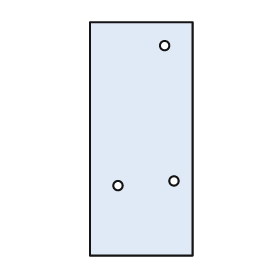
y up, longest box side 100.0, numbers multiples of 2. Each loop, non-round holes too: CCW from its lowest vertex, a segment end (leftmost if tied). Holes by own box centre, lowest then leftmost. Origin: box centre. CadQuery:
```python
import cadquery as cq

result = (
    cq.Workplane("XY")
    .moveTo(-22.0, -50.0)
    .lineTo(22.0, -50.0)
    .lineTo(22.0, 50.0)
    .lineTo(-22.0, 50.0)
    .close()
    .moveTo(-10.0, -20.0)
    .circle(2.0)
    .moveTo(14.0, -18.0)
    .circle(2.0)
    .moveTo(10.0, 40.0)
    .circle(2.0)
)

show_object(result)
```